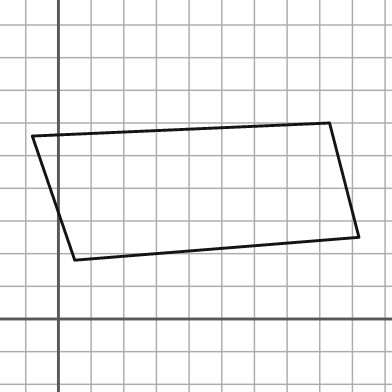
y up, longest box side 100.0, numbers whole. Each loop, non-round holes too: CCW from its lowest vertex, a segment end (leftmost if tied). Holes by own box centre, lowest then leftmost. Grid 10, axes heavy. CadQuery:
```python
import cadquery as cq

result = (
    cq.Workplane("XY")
    .moveTo(5.0, 18.0)
    .lineTo(92.0, 25.0)
    .lineTo(83.0, 60.0)
    .lineTo(-8.0, 56.0)
    .close()
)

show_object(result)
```